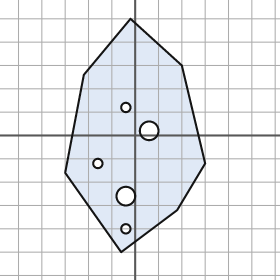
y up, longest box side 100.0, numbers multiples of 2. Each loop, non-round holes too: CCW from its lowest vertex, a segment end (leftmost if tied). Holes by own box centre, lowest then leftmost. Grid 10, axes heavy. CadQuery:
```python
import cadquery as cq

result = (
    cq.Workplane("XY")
    .moveTo(-6.0, -50.0)
    .lineTo(18.0, -32.0)
    .lineTo(30.0, -12.0)
    .lineTo(20.0, 30.0)
    .lineTo(-2.0, 50.0)
    .lineTo(-22.0, 26.0)
    .lineTo(-30.0, -16.0)
    .close()
    .moveTo(-4.0, -40.0)
    .circle(2.0)
    .moveTo(-4.0, -26.0)
    .circle(4.0)
    .moveTo(-16.0, -12.0)
    .circle(2.0)
    .moveTo(6.0, 2.0)
    .circle(4.0)
    .moveTo(-4.0, 12.0)
    .circle(2.0)
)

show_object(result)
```